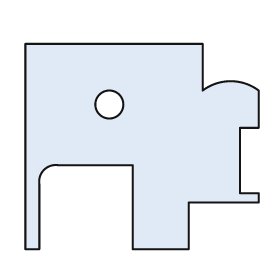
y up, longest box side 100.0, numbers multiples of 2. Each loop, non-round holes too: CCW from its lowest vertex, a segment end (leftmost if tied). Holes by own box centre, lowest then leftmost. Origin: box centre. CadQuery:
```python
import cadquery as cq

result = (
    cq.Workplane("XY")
    .moveTo(-50.0, -44.0)
    .lineTo(-44.0, -44.0)
    .lineTo(-44.0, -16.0)
    .threePointArc((-42.0, -10.0), (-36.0, -8.0))
    .lineTo(-4.0, -8.0)
    .lineTo(-4.0, -44.0)
    .lineTo(20.0, -44.0)
    .lineTo(20.0, -24.0)
    .lineTo(50.0, -24.0)
    .lineTo(50.0, -20.0)
    .lineTo(42.0, -20.0)
    .lineTo(42.0, 8.0)
    .lineTo(50.0, 8.0)
    .lineTo(50.0, 24.0)
    .threePointArc((38.0, 28.0), (26.0, 24.0))
    .lineTo(26.0, 44.0)
    .lineTo(-50.0, 44.0)
    .close()
    .moveTo(-14.0, 18.0)
    .circle(6.0)
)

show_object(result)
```